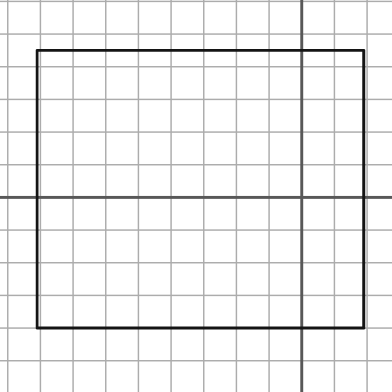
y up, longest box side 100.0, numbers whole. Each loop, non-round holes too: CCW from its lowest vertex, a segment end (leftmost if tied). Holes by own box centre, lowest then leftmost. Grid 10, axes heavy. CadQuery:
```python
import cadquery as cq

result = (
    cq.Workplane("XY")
    .moveTo(-81.0, -40.0)
    .lineTo(19.0, -40.0)
    .lineTo(19.0, 45.0)
    .lineTo(-81.0, 45.0)
    .close()
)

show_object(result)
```